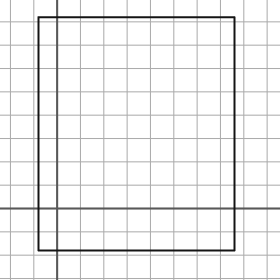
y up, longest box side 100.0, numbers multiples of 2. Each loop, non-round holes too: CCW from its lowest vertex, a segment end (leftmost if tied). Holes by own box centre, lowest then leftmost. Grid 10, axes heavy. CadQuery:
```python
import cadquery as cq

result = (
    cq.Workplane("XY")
    .moveTo(-8.0, -18.0)
    .lineTo(76.0, -18.0)
    .lineTo(76.0, 82.0)
    .lineTo(-8.0, 82.0)
    .close()
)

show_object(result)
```